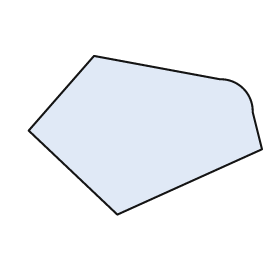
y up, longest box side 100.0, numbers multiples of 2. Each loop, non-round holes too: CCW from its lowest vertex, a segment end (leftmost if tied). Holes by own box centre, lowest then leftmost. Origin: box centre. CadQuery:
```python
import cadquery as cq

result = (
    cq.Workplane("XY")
    .moveTo(-12.0, -34.0)
    .lineTo(50.0, -6.0)
    .lineTo(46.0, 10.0)
    .threePointArc((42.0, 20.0), (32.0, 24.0))
    .lineTo(-22.0, 34.0)
    .lineTo(-50.0, 2.0)
    .close()
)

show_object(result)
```